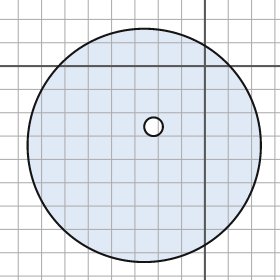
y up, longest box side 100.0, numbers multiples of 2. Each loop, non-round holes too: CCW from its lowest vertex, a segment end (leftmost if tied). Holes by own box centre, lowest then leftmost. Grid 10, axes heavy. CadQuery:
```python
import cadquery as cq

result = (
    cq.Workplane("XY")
    .moveTo(-26.0, -34.0)
    .circle(50.0)
    .moveTo(-22.0, -26.0)
    .circle(4.0)
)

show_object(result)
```